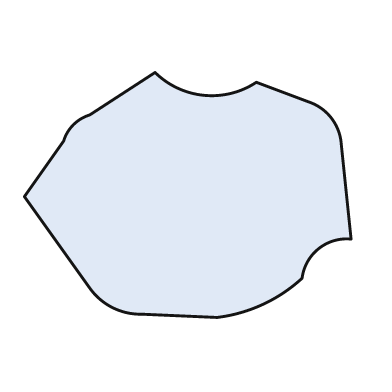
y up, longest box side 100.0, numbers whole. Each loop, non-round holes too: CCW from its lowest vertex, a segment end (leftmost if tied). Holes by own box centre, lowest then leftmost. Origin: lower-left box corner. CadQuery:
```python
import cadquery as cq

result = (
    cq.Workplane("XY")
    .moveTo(59.0, 0.0)
    .threePointArc((73.0, 4.0), (85.0, 12.0))
    .threePointArc((90.0, 21.0), (100.0, 24.0))
    .lineTo(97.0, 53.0)
    .threePointArc((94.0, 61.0), (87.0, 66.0))
    .lineTo(71.0, 72.0)
    .threePointArc((55.0, 68.0), (40.0, 75.0))
    .lineTo(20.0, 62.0)
    .threePointArc((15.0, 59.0), (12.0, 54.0))
    .lineTo(0.0, 37.0)
    .lineTo(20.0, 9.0)
    .threePointArc((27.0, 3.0), (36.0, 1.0))
    .close()
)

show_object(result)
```